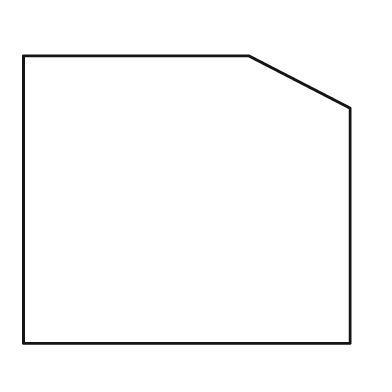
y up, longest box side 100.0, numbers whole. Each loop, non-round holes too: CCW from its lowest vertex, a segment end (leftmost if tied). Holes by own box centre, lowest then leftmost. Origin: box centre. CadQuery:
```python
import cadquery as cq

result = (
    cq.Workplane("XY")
    .moveTo(-50.0, -44.0)
    .lineTo(50.0, -44.0)
    .lineTo(50.0, 28.0)
    .lineTo(19.0, 44.0)
    .lineTo(-50.0, 44.0)
    .close()
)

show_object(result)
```